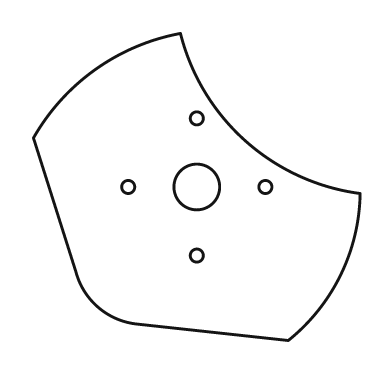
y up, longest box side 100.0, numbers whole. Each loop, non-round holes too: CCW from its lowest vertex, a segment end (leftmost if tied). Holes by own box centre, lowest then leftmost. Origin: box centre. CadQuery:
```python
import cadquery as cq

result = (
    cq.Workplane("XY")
    .moveTo(28.0, -47.0)
    .threePointArc((44.0, -27.0), (50.0, -2.0))
    .threePointArc((15.0, 14.0), (-5.0, 47.0))
    .threePointArc((-31.0, 36.0), (-50.0, 15.0))
    .lineTo(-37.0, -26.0)
    .threePointArc((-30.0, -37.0), (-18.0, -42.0))
    .close()
    .moveTo(0.0, -21.0)
    .circle(2.0)
    .moveTo(-21.0, 0.0)
    .circle(2.0)
    .moveTo(0.0, 0.0)
    .circle(7.0)
    .moveTo(21.0, 0.0)
    .circle(2.0)
    .moveTo(0.0, 21.0)
    .circle(2.0)
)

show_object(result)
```